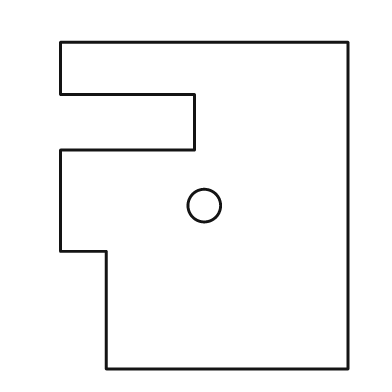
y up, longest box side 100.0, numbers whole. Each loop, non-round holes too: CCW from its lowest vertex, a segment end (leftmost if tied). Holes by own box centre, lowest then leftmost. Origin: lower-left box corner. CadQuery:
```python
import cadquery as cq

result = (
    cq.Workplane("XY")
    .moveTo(14.0, 0.0)
    .lineTo(88.0, 0.0)
    .lineTo(88.0, 100.0)
    .lineTo(0.0, 100.0)
    .lineTo(0.0, 84.0)
    .lineTo(41.0, 84.0)
    .lineTo(41.0, 67.0)
    .lineTo(0.0, 67.0)
    .lineTo(0.0, 36.0)
    .lineTo(14.0, 36.0)
    .close()
    .moveTo(44.0, 50.0)
    .circle(5.0)
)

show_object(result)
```